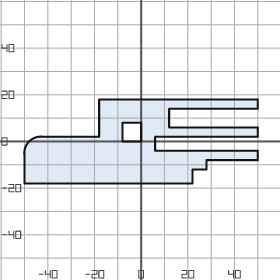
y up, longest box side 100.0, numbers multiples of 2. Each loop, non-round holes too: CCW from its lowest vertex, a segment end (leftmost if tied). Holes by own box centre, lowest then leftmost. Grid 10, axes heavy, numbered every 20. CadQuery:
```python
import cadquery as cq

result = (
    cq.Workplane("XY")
    .moveTo(-50.0, -18.0)
    .lineTo(22.0, -18.0)
    .lineTo(22.0, -12.0)
    .lineTo(28.0, -12.0)
    .lineTo(28.0, -8.0)
    .lineTo(50.0, -8.0)
    .lineTo(50.0, -4.0)
    .lineTo(6.0, -4.0)
    .lineTo(6.0, 2.0)
    .lineTo(50.0, 2.0)
    .lineTo(50.0, 6.0)
    .lineTo(12.0, 6.0)
    .lineTo(12.0, 14.0)
    .lineTo(50.0, 14.0)
    .lineTo(50.0, 18.0)
    .lineTo(-18.0, 18.0)
    .lineTo(-18.0, 2.0)
    .lineTo(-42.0, 2.0)
    .threePointArc((-48.0, 0.0), (-50.0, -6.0))
    .close()
    .moveTo(-8.0, 0.0)
    .lineTo(0.0, 0.0)
    .lineTo(0.0, 8.0)
    .lineTo(-8.0, 8.0)
    .close()
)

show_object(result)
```